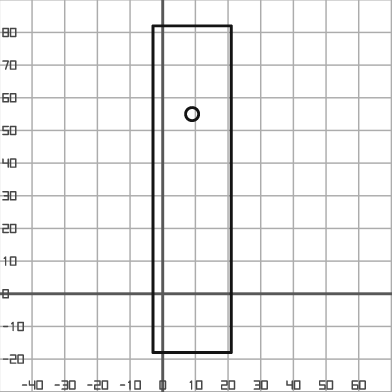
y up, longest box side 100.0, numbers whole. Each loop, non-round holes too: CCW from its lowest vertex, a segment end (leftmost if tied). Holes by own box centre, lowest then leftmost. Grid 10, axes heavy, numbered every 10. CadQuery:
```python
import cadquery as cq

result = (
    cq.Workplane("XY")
    .moveTo(-3.0, -18.0)
    .lineTo(21.0, -18.0)
    .lineTo(21.0, 82.0)
    .lineTo(-3.0, 82.0)
    .close()
    .moveTo(9.0, 55.0)
    .circle(2.0)
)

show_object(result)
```